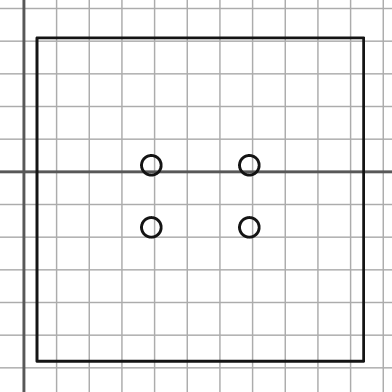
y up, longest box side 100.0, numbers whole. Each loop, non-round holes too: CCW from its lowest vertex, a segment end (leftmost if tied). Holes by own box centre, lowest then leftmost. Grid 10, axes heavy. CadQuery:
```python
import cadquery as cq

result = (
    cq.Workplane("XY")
    .moveTo(4.0, -58.0)
    .lineTo(104.0, -58.0)
    .lineTo(104.0, 41.0)
    .lineTo(4.0, 41.0)
    .close()
    .moveTo(39.0, -17.0)
    .circle(3.0)
    .moveTo(69.0, -17.0)
    .circle(3.0)
    .moveTo(39.0, 2.0)
    .circle(3.0)
    .moveTo(69.0, 2.0)
    .circle(3.0)
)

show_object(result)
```